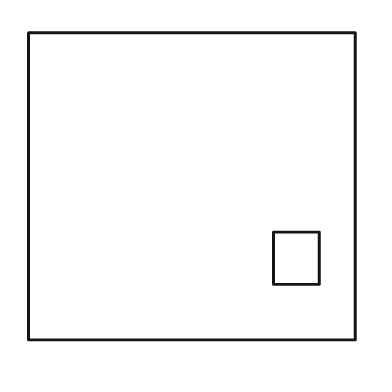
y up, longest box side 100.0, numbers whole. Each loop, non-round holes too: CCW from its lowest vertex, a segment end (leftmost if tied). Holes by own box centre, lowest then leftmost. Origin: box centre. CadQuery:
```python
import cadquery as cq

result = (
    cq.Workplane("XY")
    .moveTo(-50.0, -47.0)
    .lineTo(50.0, -47.0)
    .lineTo(50.0, 47.0)
    .lineTo(-50.0, 47.0)
    .close()
    .moveTo(25.0, -30.0)
    .lineTo(39.0, -30.0)
    .lineTo(39.0, -14.0)
    .lineTo(25.0, -14.0)
    .close()
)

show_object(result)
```